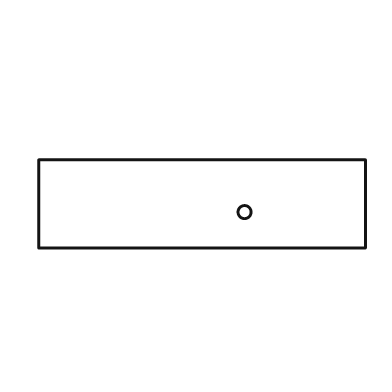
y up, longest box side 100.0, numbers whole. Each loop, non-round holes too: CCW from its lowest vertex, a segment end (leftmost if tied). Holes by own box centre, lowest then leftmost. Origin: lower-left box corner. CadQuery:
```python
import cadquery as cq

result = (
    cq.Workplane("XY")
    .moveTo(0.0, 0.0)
    .lineTo(100.0, 0.0)
    .lineTo(100.0, 27.0)
    .lineTo(0.0, 27.0)
    .close()
    .moveTo(63.0, 11.0)
    .circle(2.0)
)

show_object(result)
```